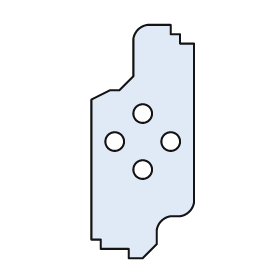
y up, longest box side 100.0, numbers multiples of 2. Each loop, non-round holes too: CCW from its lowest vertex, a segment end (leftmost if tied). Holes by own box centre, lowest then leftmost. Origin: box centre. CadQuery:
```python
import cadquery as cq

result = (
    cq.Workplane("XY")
    .moveTo(-6.0, -50.0)
    .lineTo(0.0, -50.0)
    .lineTo(6.0, -44.0)
    .lineTo(6.0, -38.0)
    .threePointArc((8.0, -34.0), (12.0, -32.0))
    .lineTo(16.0, -32.0)
    .threePointArc((20.0, -30.0), (22.0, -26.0))
    .lineTo(22.0, 42.0)
    .lineTo(16.0, 42.0)
    .lineTo(16.0, 46.0)
    .lineTo(12.0, 46.0)
    .lineTo(12.0, 50.0)
    .lineTo(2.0, 50.0)
    .threePointArc((-2.0, 48.0), (-4.0, 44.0))
    .lineTo(-4.0, 28.0)
    .lineTo(-10.0, 22.0)
    .lineTo(-14.0, 22.0)
    .lineTo(-22.0, 18.0)
    .lineTo(-22.0, -42.0)
    .lineTo(-18.0, -42.0)
    .lineTo(-18.0, -46.0)
    .lineTo(-6.0, -46.0)
    .close()
    .moveTo(0.0, -12.0)
    .circle(4.0)
    .moveTo(-12.0, 0.0)
    .circle(4.0)
    .moveTo(12.0, 0.0)
    .circle(4.0)
    .moveTo(0.0, 12.0)
    .circle(4.0)
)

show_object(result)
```